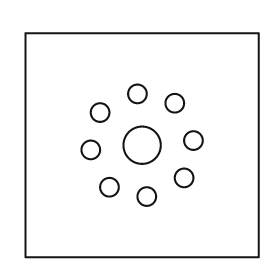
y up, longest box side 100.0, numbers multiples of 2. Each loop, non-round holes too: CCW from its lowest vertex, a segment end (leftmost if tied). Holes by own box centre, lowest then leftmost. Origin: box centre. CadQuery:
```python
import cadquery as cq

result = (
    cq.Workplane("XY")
    .moveTo(-50.0, -48.0)
    .lineTo(50.0, -48.0)
    .lineTo(50.0, 48.0)
    .lineTo(-50.0, 48.0)
    .close()
    .moveTo(2.0, -22.0)
    .circle(4.0)
    .moveTo(-14.0, -18.0)
    .circle(4.0)
    .moveTo(18.0, -14.0)
    .circle(4.0)
    .moveTo(-22.0, -2.0)
    .circle(4.0)
    .moveTo(0.0, 0.0)
    .circle(8.0)
    .moveTo(22.0, 2.0)
    .circle(4.0)
    .moveTo(-18.0, 14.0)
    .circle(4.0)
    .moveTo(14.0, 18.0)
    .circle(4.0)
    .moveTo(-2.0, 22.0)
    .circle(4.0)
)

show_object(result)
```